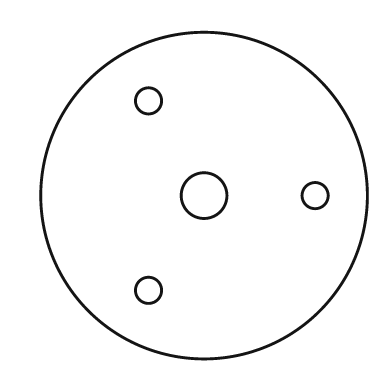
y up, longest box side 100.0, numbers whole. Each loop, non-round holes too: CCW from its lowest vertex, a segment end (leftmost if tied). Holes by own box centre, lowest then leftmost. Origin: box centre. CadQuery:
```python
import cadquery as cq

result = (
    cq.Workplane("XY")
    .moveTo(0.0, 0.0)
    .circle(50.0)
    .moveTo(-17.0, -29.0)
    .circle(4.0)
    .moveTo(0.0, 0.0)
    .circle(7.0)
    .moveTo(34.0, 0.0)
    .circle(4.0)
    .moveTo(-17.0, 29.0)
    .circle(4.0)
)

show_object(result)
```